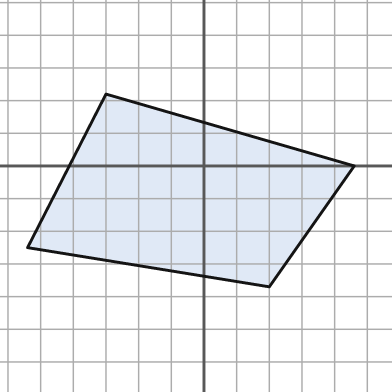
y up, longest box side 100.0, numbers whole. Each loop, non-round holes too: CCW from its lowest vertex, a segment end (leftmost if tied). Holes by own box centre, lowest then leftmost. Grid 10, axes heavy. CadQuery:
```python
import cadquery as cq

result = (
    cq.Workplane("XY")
    .moveTo(20.0, -37.0)
    .lineTo(46.0, 0.0)
    .lineTo(-30.0, 22.0)
    .lineTo(-54.0, -25.0)
    .close()
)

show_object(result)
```